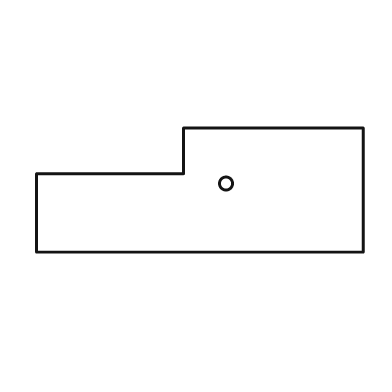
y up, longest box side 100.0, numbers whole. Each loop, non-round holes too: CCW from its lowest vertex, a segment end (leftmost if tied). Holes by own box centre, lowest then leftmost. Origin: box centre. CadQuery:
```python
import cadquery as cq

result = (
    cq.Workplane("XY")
    .moveTo(-50.0, -19.0)
    .lineTo(50.0, -19.0)
    .lineTo(50.0, 19.0)
    .lineTo(-5.0, 19.0)
    .lineTo(-5.0, 5.0)
    .lineTo(-50.0, 5.0)
    .close()
    .moveTo(8.0, 2.0)
    .circle(2.0)
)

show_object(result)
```